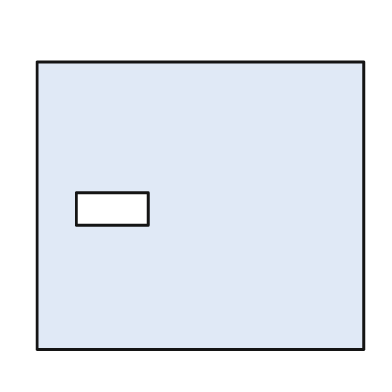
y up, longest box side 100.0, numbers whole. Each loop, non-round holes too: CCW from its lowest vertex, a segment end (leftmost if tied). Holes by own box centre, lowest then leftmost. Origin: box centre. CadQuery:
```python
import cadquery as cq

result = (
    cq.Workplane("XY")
    .moveTo(-50.0, -44.0)
    .lineTo(50.0, -44.0)
    .lineTo(50.0, 44.0)
    .lineTo(-50.0, 44.0)
    .close()
    .moveTo(-38.0, -6.0)
    .lineTo(-16.0, -6.0)
    .lineTo(-16.0, 4.0)
    .lineTo(-38.0, 4.0)
    .close()
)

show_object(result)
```